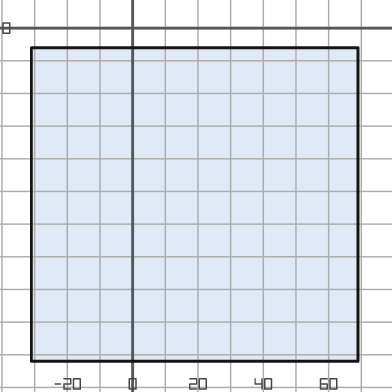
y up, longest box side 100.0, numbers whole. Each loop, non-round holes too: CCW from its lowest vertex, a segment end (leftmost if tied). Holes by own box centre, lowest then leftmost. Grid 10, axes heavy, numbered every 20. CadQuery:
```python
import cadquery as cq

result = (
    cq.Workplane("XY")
    .moveTo(-31.0, -102.0)
    .lineTo(69.0, -102.0)
    .lineTo(69.0, -6.0)
    .lineTo(-31.0, -6.0)
    .close()
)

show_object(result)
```